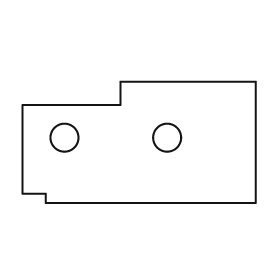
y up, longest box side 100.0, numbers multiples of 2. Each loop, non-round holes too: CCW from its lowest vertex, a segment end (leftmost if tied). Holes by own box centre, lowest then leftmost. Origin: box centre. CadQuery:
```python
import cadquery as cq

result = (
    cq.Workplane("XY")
    .moveTo(-40.0, -26.0)
    .lineTo(50.0, -26.0)
    .lineTo(50.0, 26.0)
    .lineTo(-8.0, 26.0)
    .lineTo(-8.0, 16.0)
    .lineTo(-50.0, 16.0)
    .lineTo(-50.0, -22.0)
    .lineTo(-40.0, -22.0)
    .close()
    .moveTo(-32.0, 2.0)
    .circle(6.0)
    .moveTo(12.0, 2.0)
    .circle(6.0)
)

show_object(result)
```